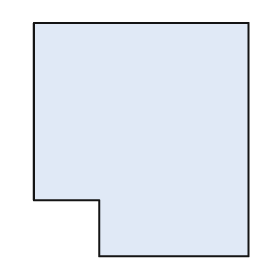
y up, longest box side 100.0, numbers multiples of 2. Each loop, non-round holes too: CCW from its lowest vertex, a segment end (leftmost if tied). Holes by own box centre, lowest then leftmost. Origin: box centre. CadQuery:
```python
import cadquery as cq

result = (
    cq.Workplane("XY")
    .moveTo(-18.0, -50.0)
    .lineTo(46.0, -50.0)
    .lineTo(46.0, 50.0)
    .lineTo(-46.0, 50.0)
    .lineTo(-46.0, -26.0)
    .lineTo(-18.0, -26.0)
    .close()
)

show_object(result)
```